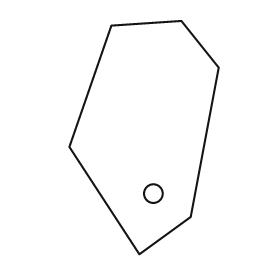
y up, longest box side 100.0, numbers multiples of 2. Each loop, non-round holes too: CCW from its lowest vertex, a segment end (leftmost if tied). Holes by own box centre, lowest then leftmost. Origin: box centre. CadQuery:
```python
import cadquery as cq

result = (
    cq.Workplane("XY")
    .moveTo(-2.0, -50.0)
    .lineTo(20.0, -34.0)
    .lineTo(32.0, 30.0)
    .lineTo(16.0, 50.0)
    .lineTo(-14.0, 48.0)
    .lineTo(-32.0, -4.0)
    .close()
    .moveTo(4.0, -24.0)
    .circle(4.0)
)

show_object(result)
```